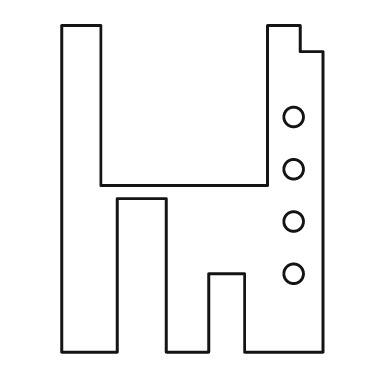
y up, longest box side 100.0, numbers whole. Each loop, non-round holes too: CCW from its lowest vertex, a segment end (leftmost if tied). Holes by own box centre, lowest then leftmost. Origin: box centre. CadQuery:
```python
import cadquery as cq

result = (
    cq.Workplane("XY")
    .moveTo(-40.0, -50.0)
    .lineTo(-23.0, -50.0)
    .lineTo(-23.0, -3.0)
    .lineTo(-8.0, -3.0)
    .lineTo(-8.0, -50.0)
    .lineTo(5.0, -50.0)
    .lineTo(5.0, -26.0)
    .lineTo(16.0, -26.0)
    .lineTo(16.0, -50.0)
    .lineTo(40.0, -50.0)
    .lineTo(40.0, 42.0)
    .lineTo(33.0, 42.0)
    .lineTo(33.0, 50.0)
    .lineTo(23.0, 50.0)
    .lineTo(23.0, 1.0)
    .lineTo(-28.0, 1.0)
    .lineTo(-28.0, 50.0)
    .lineTo(-40.0, 50.0)
    .close()
    .moveTo(31.0, -26.0)
    .circle(3.0)
    .moveTo(31.0, -10.0)
    .circle(3.0)
    .moveTo(31.0, 6.0)
    .circle(3.0)
    .moveTo(31.0, 22.0)
    .circle(3.0)
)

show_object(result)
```